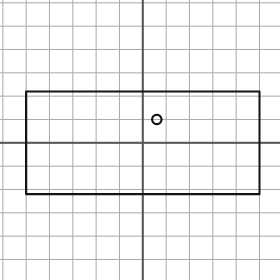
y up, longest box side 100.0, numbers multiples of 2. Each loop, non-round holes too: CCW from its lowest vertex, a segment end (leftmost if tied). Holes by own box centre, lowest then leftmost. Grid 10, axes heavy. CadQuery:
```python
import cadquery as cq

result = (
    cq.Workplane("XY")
    .moveTo(-50.0, -22.0)
    .lineTo(50.0, -22.0)
    .lineTo(50.0, 22.0)
    .lineTo(-50.0, 22.0)
    .close()
    .moveTo(6.0, 10.0)
    .circle(2.0)
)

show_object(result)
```